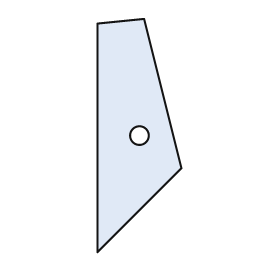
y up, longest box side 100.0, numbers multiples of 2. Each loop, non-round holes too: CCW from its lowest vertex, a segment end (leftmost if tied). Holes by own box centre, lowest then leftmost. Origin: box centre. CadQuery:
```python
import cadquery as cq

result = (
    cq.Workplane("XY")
    .moveTo(-18.0, -50.0)
    .lineTo(18.0, -14.0)
    .lineTo(2.0, 50.0)
    .lineTo(-18.0, 48.0)
    .close()
    .moveTo(0.0, 0.0)
    .circle(4.0)
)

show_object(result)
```